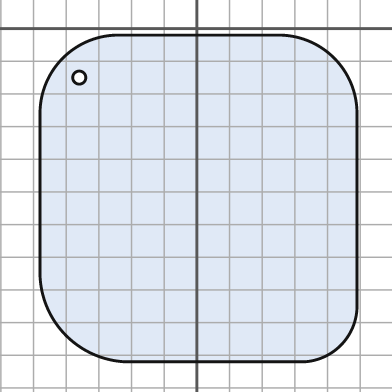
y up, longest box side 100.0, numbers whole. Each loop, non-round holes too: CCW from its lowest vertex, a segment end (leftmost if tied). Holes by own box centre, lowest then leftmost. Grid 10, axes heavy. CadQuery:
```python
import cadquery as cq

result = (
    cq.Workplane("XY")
    .moveTo(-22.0, -102.0)
    .lineTo(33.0, -102.0)
    .threePointArc((44.0, -97.0), (49.0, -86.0))
    .lineTo(49.0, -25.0)
    .threePointArc((42.0, -9.0), (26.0, -2.0))
    .lineTo(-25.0, -2.0)
    .threePointArc((-41.0, -9.0), (-48.0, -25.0))
    .lineTo(-48.0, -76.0)
    .threePointArc((-40.0, -94.0), (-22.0, -102.0))
    .close()
    .moveTo(-36.0, -15.0)
    .circle(2.0)
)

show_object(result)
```